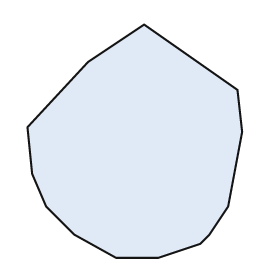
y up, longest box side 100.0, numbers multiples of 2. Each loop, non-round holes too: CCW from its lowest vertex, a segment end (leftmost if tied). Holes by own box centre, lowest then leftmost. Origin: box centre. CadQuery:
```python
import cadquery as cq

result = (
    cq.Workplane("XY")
    .moveTo(-8.0, -50.0)
    .lineTo(10.0, -50.0)
    .lineTo(28.0, -44.0)
    .lineTo(32.0, -40.0)
    .lineTo(40.0, -28.0)
    .lineTo(46.0, 4.0)
    .lineTo(44.0, 22.0)
    .lineTo(4.0, 50.0)
    .lineTo(-20.0, 34.0)
    .lineTo(-46.0, 6.0)
    .lineTo(-44.0, -14.0)
    .lineTo(-38.0, -28.0)
    .lineTo(-26.0, -40.0)
    .close()
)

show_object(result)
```